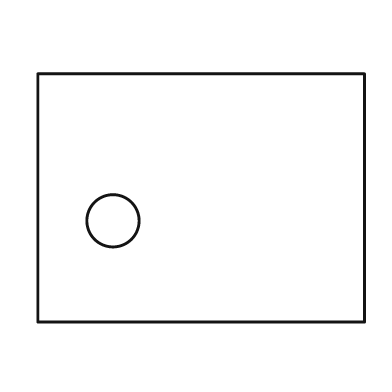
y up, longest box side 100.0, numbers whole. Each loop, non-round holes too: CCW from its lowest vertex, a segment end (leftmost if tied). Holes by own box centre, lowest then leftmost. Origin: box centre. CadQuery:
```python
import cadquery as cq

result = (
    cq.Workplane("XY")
    .moveTo(-50.0, -38.0)
    .lineTo(50.0, -38.0)
    .lineTo(50.0, 38.0)
    .lineTo(-50.0, 38.0)
    .close()
    .moveTo(-27.0, -7.0)
    .circle(8.0)
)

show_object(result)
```